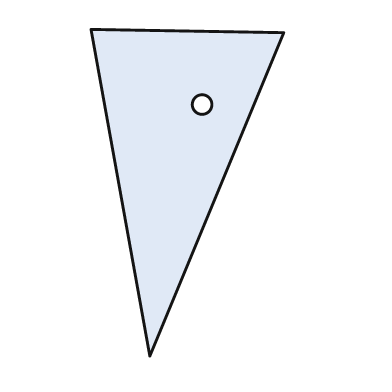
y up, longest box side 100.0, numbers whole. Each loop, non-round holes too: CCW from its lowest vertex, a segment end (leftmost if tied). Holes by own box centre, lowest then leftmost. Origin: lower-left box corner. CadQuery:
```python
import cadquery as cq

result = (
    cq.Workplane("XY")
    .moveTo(18.0, 0.0)
    .lineTo(59.0, 99.0)
    .lineTo(0.0, 100.0)
    .close()
    .moveTo(34.0, 77.0)
    .circle(3.0)
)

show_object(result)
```